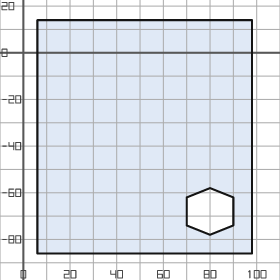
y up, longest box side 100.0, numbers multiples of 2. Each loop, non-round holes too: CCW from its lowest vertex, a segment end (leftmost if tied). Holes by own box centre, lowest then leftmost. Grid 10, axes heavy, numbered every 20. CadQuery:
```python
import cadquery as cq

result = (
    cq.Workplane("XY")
    .moveTo(6.0, -86.0)
    .lineTo(98.0, -86.0)
    .lineTo(98.0, 14.0)
    .lineTo(6.0, 14.0)
    .close()
    .moveTo(80.0, -78.0)
    .lineTo(90.0, -74.0)
    .lineTo(90.0, -62.0)
    .lineTo(80.0, -58.0)
    .lineTo(70.0, -62.0)
    .lineTo(70.0, -74.0)
    .close()
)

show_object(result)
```